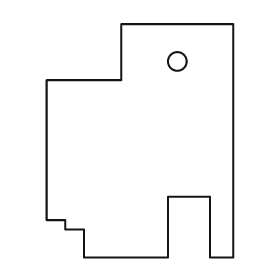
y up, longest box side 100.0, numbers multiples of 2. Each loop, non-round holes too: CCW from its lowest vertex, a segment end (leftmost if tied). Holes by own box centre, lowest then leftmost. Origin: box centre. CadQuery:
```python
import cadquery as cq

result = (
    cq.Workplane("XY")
    .moveTo(-24.0, -50.0)
    .lineTo(12.0, -50.0)
    .lineTo(12.0, -24.0)
    .lineTo(30.0, -24.0)
    .lineTo(30.0, -50.0)
    .lineTo(40.0, -50.0)
    .lineTo(40.0, 50.0)
    .lineTo(-8.0, 50.0)
    .lineTo(-8.0, 26.0)
    .lineTo(-40.0, 26.0)
    .lineTo(-40.0, -34.0)
    .lineTo(-32.0, -34.0)
    .lineTo(-32.0, -38.0)
    .lineTo(-24.0, -38.0)
    .close()
    .moveTo(16.0, 34.0)
    .circle(4.0)
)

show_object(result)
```